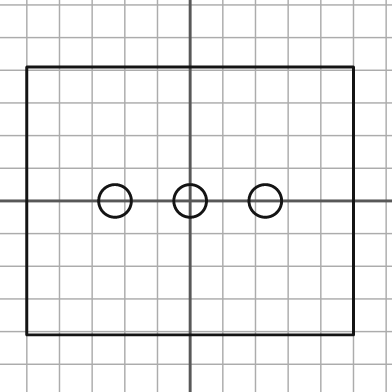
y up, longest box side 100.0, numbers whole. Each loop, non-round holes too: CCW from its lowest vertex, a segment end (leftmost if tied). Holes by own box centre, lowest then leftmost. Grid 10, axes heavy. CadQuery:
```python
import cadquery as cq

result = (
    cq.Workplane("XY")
    .moveTo(-50.0, -41.0)
    .lineTo(50.0, -41.0)
    .lineTo(50.0, 41.0)
    .lineTo(-50.0, 41.0)
    .close()
    .moveTo(-23.0, 0.0)
    .circle(5.0)
    .moveTo(0.0, 0.0)
    .circle(5.0)
    .moveTo(23.0, 0.0)
    .circle(5.0)
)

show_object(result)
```